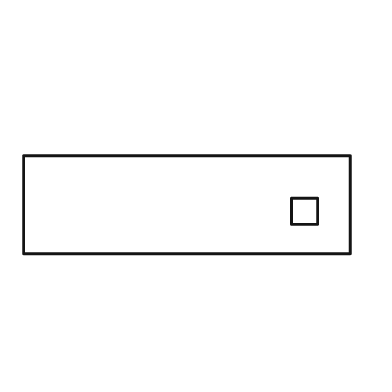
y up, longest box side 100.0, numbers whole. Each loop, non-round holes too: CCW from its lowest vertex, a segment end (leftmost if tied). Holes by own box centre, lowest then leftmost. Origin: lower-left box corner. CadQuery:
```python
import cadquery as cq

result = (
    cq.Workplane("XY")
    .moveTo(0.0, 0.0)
    .lineTo(100.0, 0.0)
    .lineTo(100.0, 30.0)
    .lineTo(0.0, 30.0)
    .close()
    .moveTo(82.0, 9.0)
    .lineTo(90.0, 9.0)
    .lineTo(90.0, 17.0)
    .lineTo(82.0, 17.0)
    .close()
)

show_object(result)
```